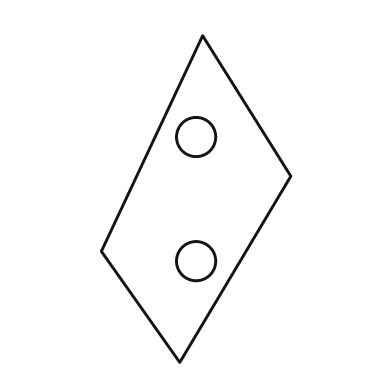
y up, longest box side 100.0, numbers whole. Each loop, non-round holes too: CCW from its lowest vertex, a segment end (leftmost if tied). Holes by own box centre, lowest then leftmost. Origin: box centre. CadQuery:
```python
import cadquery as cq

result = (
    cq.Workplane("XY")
    .moveTo(-5.0, -50.0)
    .lineTo(29.0, 7.0)
    .lineTo(2.0, 50.0)
    .lineTo(-29.0, -16.0)
    .close()
    .moveTo(0.0, -19.0)
    .circle(6.0)
    .moveTo(0.0, 19.0)
    .circle(6.0)
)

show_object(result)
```